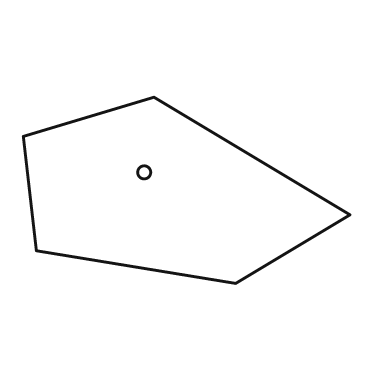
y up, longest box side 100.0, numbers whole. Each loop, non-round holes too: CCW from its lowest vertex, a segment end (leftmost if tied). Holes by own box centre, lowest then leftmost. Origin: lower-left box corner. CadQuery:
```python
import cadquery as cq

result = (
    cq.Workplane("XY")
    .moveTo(65.0, 0.0)
    .lineTo(100.0, 21.0)
    .lineTo(40.0, 57.0)
    .lineTo(0.0, 45.0)
    .lineTo(4.0, 10.0)
    .close()
    .moveTo(37.0, 34.0)
    .circle(2.0)
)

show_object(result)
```